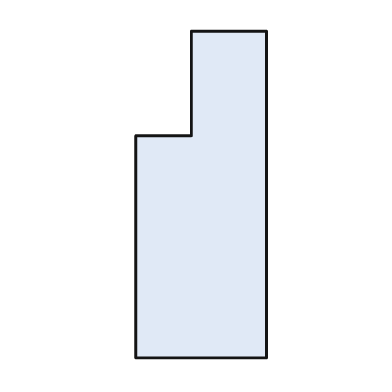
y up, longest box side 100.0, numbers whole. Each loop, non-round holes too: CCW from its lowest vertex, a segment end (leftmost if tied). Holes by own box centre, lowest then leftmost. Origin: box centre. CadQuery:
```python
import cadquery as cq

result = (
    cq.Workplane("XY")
    .moveTo(-20.0, -50.0)
    .lineTo(20.0, -50.0)
    .lineTo(20.0, 50.0)
    .lineTo(-3.0, 50.0)
    .lineTo(-3.0, 18.0)
    .lineTo(-20.0, 18.0)
    .close()
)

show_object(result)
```